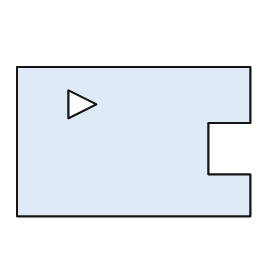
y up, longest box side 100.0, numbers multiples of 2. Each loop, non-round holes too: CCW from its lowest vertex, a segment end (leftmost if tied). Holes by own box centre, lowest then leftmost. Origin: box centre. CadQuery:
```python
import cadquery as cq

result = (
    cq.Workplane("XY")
    .moveTo(-50.0, -32.0)
    .lineTo(50.0, -32.0)
    .lineTo(50.0, -14.0)
    .lineTo(32.0, -14.0)
    .lineTo(32.0, 8.0)
    .lineTo(50.0, 8.0)
    .lineTo(50.0, 32.0)
    .lineTo(-50.0, 32.0)
    .close()
    .moveTo(-28.0, 10.0)
    .lineTo(-16.0, 16.0)
    .lineTo(-28.0, 22.0)
    .close()
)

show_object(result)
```